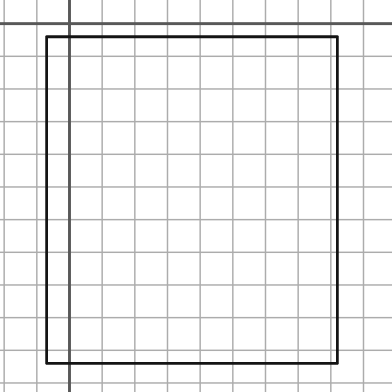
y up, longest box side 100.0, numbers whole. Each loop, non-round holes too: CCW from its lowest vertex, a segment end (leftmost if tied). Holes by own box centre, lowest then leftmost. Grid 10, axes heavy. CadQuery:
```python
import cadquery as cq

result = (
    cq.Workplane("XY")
    .moveTo(-7.0, -104.0)
    .lineTo(82.0, -104.0)
    .lineTo(82.0, -4.0)
    .lineTo(-7.0, -4.0)
    .close()
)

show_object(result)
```